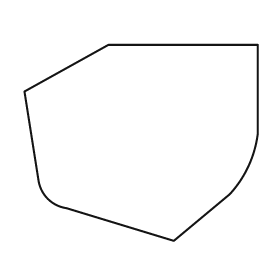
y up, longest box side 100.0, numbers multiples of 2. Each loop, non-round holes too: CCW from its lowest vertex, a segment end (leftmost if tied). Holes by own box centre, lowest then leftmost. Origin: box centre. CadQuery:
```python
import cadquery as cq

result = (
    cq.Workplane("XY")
    .moveTo(14.0, -42.0)
    .lineTo(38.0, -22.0)
    .threePointArc((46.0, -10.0), (50.0, 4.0))
    .lineTo(50.0, 42.0)
    .lineTo(-14.0, 42.0)
    .lineTo(-50.0, 22.0)
    .lineTo(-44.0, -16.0)
    .threePointArc((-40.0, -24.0), (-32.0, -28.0))
    .close()
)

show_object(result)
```